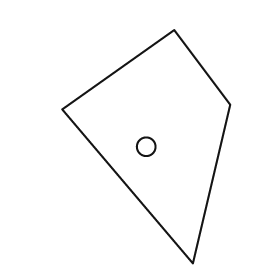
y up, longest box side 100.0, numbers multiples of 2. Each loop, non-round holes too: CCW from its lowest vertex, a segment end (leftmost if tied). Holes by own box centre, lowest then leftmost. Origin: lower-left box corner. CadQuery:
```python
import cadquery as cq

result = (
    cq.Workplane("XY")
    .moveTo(56.0, 0.0)
    .lineTo(72.0, 68.0)
    .lineTo(48.0, 100.0)
    .lineTo(0.0, 66.0)
    .close()
    .moveTo(36.0, 50.0)
    .circle(4.0)
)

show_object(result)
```